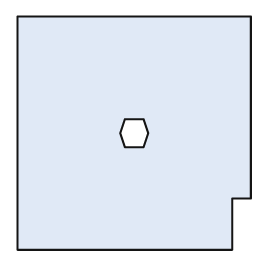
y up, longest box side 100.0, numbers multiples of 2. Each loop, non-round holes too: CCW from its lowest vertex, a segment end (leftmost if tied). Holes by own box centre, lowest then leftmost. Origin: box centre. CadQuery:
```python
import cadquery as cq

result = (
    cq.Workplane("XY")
    .moveTo(-50.0, -50.0)
    .lineTo(42.0, -50.0)
    .lineTo(42.0, -28.0)
    .lineTo(50.0, -28.0)
    .lineTo(50.0, 50.0)
    .lineTo(-50.0, 50.0)
    .close()
    .moveTo(-4.0, -6.0)
    .lineTo(4.0, -6.0)
    .lineTo(6.0, 0.0)
    .lineTo(4.0, 6.0)
    .lineTo(-4.0, 6.0)
    .lineTo(-6.0, 0.0)
    .close()
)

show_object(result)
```